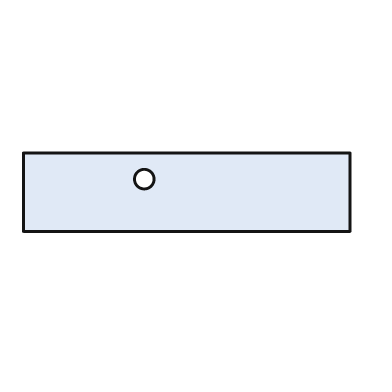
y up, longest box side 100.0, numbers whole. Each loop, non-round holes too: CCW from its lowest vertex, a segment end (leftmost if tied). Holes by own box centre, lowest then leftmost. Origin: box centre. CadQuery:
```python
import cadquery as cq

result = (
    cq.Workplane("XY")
    .moveTo(-50.0, -12.0)
    .lineTo(50.0, -12.0)
    .lineTo(50.0, 12.0)
    .lineTo(-50.0, 12.0)
    .close()
    .moveTo(-13.0, 4.0)
    .circle(3.0)
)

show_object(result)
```